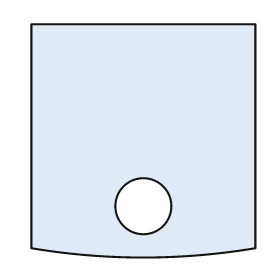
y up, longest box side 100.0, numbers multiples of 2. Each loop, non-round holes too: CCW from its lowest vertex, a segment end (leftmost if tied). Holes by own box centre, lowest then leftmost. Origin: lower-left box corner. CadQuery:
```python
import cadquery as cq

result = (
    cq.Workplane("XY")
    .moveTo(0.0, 4.0)
    .threePointArc((48.0, 0.0), (96.0, 4.0))
    .lineTo(96.0, 100.0)
    .lineTo(0.0, 100.0)
    .close()
    .moveTo(48.0, 22.0)
    .circle(12.0)
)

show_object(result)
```